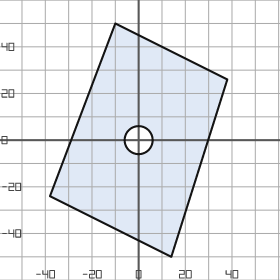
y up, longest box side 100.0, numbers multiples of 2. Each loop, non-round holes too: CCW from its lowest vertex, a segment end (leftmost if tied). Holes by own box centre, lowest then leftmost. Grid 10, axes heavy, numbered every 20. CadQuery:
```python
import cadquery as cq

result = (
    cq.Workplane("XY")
    .moveTo(14.0, -50.0)
    .lineTo(38.0, 26.0)
    .lineTo(-10.0, 50.0)
    .lineTo(-38.0, -24.0)
    .close()
    .moveTo(0.0, 0.0)
    .circle(6.0)
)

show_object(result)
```